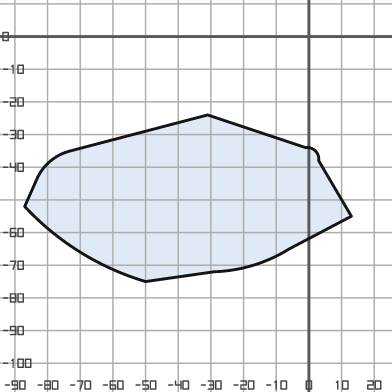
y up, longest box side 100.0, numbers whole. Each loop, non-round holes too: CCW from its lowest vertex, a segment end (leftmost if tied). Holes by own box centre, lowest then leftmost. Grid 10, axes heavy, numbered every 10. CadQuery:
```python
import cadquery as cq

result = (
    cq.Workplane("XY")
    .moveTo(-50.0, -75.0)
    .lineTo(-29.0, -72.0)
    .threePointArc((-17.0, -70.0), (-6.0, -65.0))
    .lineTo(13.0, -55.0)
    .lineTo(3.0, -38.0)
    .threePointArc((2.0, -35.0), (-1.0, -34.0))
    .lineTo(-31.0, -24.0)
    .lineTo(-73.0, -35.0)
    .threePointArc((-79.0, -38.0), (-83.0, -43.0))
    .lineTo(-87.0, -52.0)
    .threePointArc((-70.0, -66.0), (-50.0, -75.0))
    .close()
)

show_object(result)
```